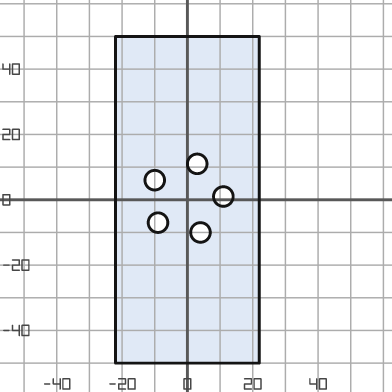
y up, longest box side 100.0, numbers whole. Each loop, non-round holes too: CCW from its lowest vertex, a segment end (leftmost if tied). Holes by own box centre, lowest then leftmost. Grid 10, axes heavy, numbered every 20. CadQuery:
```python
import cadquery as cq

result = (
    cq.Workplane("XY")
    .moveTo(-22.0, -50.0)
    .lineTo(22.0, -50.0)
    .lineTo(22.0, 50.0)
    .lineTo(-22.0, 50.0)
    .close()
    .moveTo(4.0, -10.0)
    .circle(3.0)
    .moveTo(-9.0, -7.0)
    .circle(3.0)
    .moveTo(11.0, 1.0)
    .circle(3.0)
    .moveTo(-10.0, 6.0)
    .circle(3.0)
    .moveTo(3.0, 11.0)
    .circle(3.0)
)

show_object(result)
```